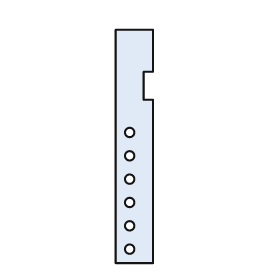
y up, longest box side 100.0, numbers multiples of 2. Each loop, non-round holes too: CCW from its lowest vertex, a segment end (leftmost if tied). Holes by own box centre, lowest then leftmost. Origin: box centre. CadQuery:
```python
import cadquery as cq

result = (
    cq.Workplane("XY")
    .moveTo(-8.0, -50.0)
    .lineTo(8.0, -50.0)
    .lineTo(8.0, 20.0)
    .lineTo(4.0, 20.0)
    .lineTo(4.0, 32.0)
    .lineTo(8.0, 32.0)
    .lineTo(8.0, 50.0)
    .lineTo(-8.0, 50.0)
    .close()
    .moveTo(-2.0, -44.0)
    .circle(2.0)
    .moveTo(-2.0, -34.0)
    .circle(2.0)
    .moveTo(-2.0, -24.0)
    .circle(2.0)
    .moveTo(-2.0, -14.0)
    .circle(2.0)
    .moveTo(-2.0, -4.0)
    .circle(2.0)
    .moveTo(-2.0, 6.0)
    .circle(2.0)
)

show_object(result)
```